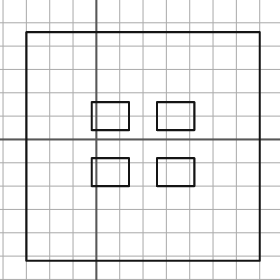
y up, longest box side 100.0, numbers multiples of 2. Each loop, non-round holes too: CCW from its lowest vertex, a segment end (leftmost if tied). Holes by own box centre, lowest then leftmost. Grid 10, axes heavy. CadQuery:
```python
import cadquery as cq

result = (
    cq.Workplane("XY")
    .moveTo(-30.0, -52.0)
    .lineTo(70.0, -52.0)
    .lineTo(70.0, 46.0)
    .lineTo(-30.0, 46.0)
    .close()
    .moveTo(-2.0, -20.0)
    .lineTo(14.0, -20.0)
    .lineTo(14.0, -8.0)
    .lineTo(-2.0, -8.0)
    .close()
    .moveTo(26.0, -20.0)
    .lineTo(42.0, -20.0)
    .lineTo(42.0, -8.0)
    .lineTo(26.0, -8.0)
    .close()
    .moveTo(-2.0, 4.0)
    .lineTo(14.0, 4.0)
    .lineTo(14.0, 16.0)
    .lineTo(-2.0, 16.0)
    .close()
    .moveTo(26.0, 4.0)
    .lineTo(42.0, 4.0)
    .lineTo(42.0, 16.0)
    .lineTo(26.0, 16.0)
    .close()
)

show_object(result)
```